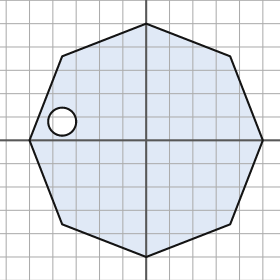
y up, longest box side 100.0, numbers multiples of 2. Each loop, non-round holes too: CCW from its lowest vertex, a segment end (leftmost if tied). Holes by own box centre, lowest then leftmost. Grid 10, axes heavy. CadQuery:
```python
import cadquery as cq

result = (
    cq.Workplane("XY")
    .moveTo(0.0, -50.0)
    .lineTo(36.0, -36.0)
    .lineTo(50.0, 0.0)
    .lineTo(36.0, 36.0)
    .lineTo(0.0, 50.0)
    .lineTo(-36.0, 36.0)
    .lineTo(-50.0, 0.0)
    .lineTo(-36.0, -36.0)
    .close()
    .moveTo(-36.0, 8.0)
    .circle(6.0)
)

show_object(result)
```